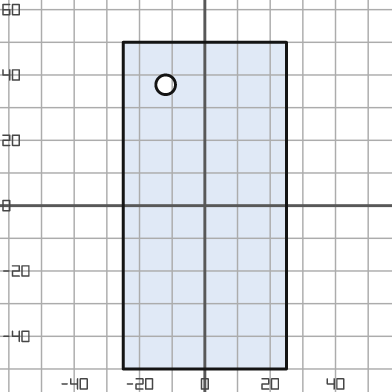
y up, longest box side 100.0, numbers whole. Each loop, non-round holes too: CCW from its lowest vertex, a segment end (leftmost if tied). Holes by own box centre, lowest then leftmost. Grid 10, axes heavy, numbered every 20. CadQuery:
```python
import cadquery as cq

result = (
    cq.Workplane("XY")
    .moveTo(-25.0, -50.0)
    .lineTo(25.0, -50.0)
    .lineTo(25.0, 50.0)
    .lineTo(-25.0, 50.0)
    .close()
    .moveTo(-12.0, 37.0)
    .circle(3.0)
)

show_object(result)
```